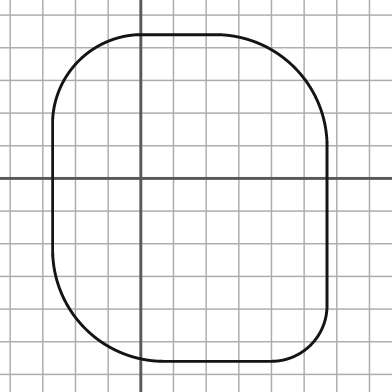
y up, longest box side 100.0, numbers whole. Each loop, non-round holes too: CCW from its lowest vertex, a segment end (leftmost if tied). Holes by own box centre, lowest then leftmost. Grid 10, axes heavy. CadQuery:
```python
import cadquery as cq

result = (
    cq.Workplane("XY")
    .moveTo(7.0, -56.0)
    .lineTo(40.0, -56.0)
    .threePointArc((52.0, -51.0), (57.0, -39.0))
    .lineTo(57.0, 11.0)
    .threePointArc((47.0, 34.0), (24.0, 44.0))
    .lineTo(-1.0, 44.0)
    .threePointArc((-19.0, 36.0), (-27.0, 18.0))
    .lineTo(-27.0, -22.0)
    .threePointArc((-17.0, -46.0), (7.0, -56.0))
    .close()
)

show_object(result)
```